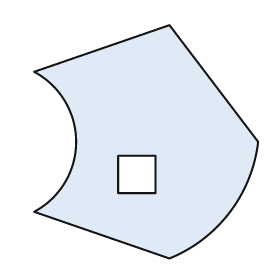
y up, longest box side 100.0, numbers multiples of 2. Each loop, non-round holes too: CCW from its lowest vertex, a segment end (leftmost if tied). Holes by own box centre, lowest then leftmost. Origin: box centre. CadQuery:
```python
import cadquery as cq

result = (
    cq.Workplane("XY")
    .moveTo(10.0, -50.0)
    .threePointArc((36.0, -30.0), (48.0, 0.0))
    .lineTo(10.0, 50.0)
    .lineTo(-48.0, 30.0)
    .threePointArc((-30.0, 0.0), (-48.0, -30.0))
    .close()
    .moveTo(-12.0, -22.0)
    .lineTo(4.0, -22.0)
    .lineTo(4.0, -6.0)
    .lineTo(-12.0, -6.0)
    .close()
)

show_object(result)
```